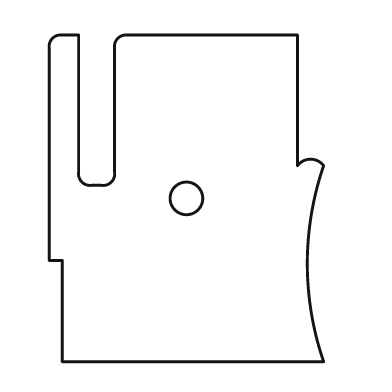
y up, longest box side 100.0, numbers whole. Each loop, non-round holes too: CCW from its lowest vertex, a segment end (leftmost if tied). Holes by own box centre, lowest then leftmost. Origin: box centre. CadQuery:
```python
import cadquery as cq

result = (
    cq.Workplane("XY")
    .moveTo(-38.0, -50.0)
    .lineTo(42.0, -50.0)
    .threePointArc((37.0, -20.0), (42.0, 10.0))
    .threePointArc((38.0, 12.0), (34.0, 10.0))
    .lineTo(34.0, 50.0)
    .lineTo(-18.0, 50.0)
    .threePointArc((-21.0, 49.0), (-22.0, 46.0))
    .lineTo(-22.0, 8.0)
    .threePointArc((-23.0, 5.0), (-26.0, 4.0))
    .lineTo(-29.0, 4.0)
    .threePointArc((-32.0, 5.0), (-33.0, 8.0))
    .lineTo(-33.0, 50.0)
    .lineTo(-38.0, 50.0)
    .threePointArc((-41.0, 49.0), (-42.0, 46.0))
    .lineTo(-42.0, -19.0)
    .lineTo(-38.0, -19.0)
    .close()
    .moveTo(0.0, 0.0)
    .circle(5.0)
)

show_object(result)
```